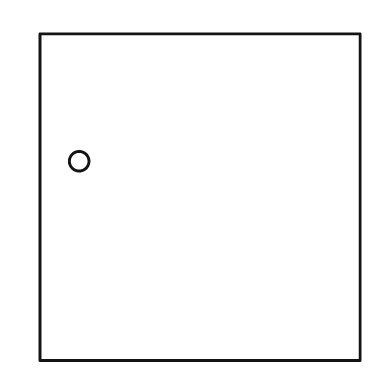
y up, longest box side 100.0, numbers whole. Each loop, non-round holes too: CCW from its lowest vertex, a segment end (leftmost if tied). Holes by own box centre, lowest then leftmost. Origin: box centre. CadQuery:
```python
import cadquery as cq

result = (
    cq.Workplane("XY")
    .moveTo(-49.0, -50.0)
    .lineTo(49.0, -50.0)
    .lineTo(49.0, 50.0)
    .lineTo(-49.0, 50.0)
    .close()
    .moveTo(-37.0, 11.0)
    .circle(3.0)
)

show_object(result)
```